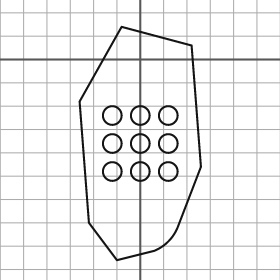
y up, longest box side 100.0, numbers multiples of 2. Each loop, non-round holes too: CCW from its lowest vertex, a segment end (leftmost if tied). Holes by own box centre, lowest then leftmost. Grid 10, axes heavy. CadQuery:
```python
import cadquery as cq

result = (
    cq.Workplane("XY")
    .moveTo(-10.0, -86.0)
    .lineTo(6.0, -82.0)
    .threePointArc((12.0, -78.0), (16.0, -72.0))
    .lineTo(26.0, -46.0)
    .lineTo(22.0, 6.0)
    .lineTo(-8.0, 14.0)
    .lineTo(-26.0, -18.0)
    .lineTo(-22.0, -70.0)
    .close()
    .moveTo(-12.0, -48.0)
    .circle(4.0)
    .moveTo(0.0, -48.0)
    .circle(4.0)
    .moveTo(12.0, -48.0)
    .circle(4.0)
    .moveTo(-12.0, -36.0)
    .circle(4.0)
    .moveTo(0.0, -36.0)
    .circle(4.0)
    .moveTo(12.0, -36.0)
    .circle(4.0)
    .moveTo(-12.0, -24.0)
    .circle(4.0)
    .moveTo(0.0, -24.0)
    .circle(4.0)
    .moveTo(12.0, -24.0)
    .circle(4.0)
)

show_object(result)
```